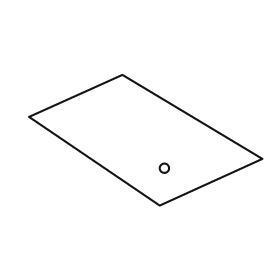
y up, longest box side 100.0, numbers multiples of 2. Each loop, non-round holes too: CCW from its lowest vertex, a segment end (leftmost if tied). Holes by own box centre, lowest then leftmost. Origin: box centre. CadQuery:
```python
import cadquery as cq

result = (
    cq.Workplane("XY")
    .moveTo(6.0, -28.0)
    .lineTo(50.0, -8.0)
    .lineTo(-10.0, 28.0)
    .lineTo(-50.0, 10.0)
    .close()
    .moveTo(8.0, -12.0)
    .circle(2.0)
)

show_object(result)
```